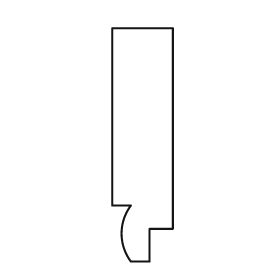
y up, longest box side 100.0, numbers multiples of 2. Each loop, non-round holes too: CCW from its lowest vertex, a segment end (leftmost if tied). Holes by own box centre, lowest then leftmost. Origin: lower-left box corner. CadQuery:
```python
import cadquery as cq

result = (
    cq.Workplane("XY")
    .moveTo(8.0, 0.0)
    .lineTo(16.0, 0.0)
    .lineTo(16.0, 14.0)
    .lineTo(26.0, 14.0)
    .lineTo(26.0, 100.0)
    .lineTo(0.0, 100.0)
    .lineTo(0.0, 24.0)
    .lineTo(8.0, 24.0)
    .threePointArc((4.0, 12.0), (8.0, 0.0))
    .close()
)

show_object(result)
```